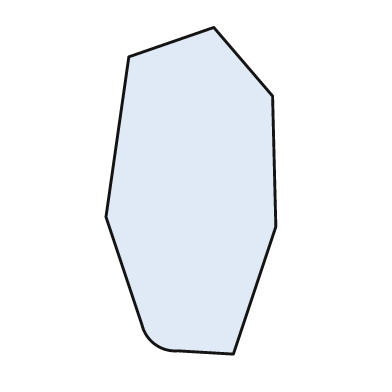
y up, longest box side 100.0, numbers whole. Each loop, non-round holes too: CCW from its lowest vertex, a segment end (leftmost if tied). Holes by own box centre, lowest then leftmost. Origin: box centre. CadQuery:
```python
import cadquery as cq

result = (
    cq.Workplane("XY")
    .moveTo(13.0, -50.0)
    .lineTo(26.0, -11.0)
    .lineTo(25.0, 29.0)
    .lineTo(7.0, 50.0)
    .lineTo(-19.0, 41.0)
    .lineTo(-26.0, -8.0)
    .lineTo(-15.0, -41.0)
    .threePointArc((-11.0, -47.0), (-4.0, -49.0))
    .close()
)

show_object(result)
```